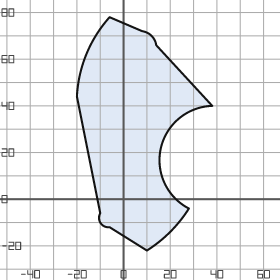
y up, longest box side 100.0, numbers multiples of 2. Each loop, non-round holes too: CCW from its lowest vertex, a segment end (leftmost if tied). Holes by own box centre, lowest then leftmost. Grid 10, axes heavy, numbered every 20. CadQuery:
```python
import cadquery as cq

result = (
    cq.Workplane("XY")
    .moveTo(10.0, -22.0)
    .threePointArc((20.0, -14.0), (28.0, -4.0))
    .threePointArc((16.0, 22.0), (38.0, 40.0))
    .lineTo(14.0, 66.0)
    .threePointArc((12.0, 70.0), (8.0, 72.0))
    .lineTo(-6.0, 78.0)
    .threePointArc((-16.0, 62.0), (-20.0, 44.0))
    .lineTo(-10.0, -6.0)
    .threePointArc((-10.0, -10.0), (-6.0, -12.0))
    .close()
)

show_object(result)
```